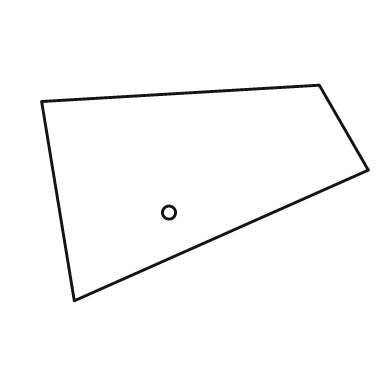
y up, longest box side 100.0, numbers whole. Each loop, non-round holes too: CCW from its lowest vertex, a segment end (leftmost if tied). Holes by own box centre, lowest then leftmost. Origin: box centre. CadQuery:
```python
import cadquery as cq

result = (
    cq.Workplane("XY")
    .moveTo(-40.0, -33.0)
    .lineTo(50.0, 7.0)
    .lineTo(35.0, 33.0)
    .lineTo(-50.0, 28.0)
    .close()
    .moveTo(-11.0, -6.0)
    .circle(2.0)
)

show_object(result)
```